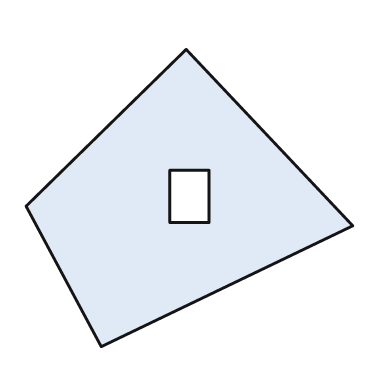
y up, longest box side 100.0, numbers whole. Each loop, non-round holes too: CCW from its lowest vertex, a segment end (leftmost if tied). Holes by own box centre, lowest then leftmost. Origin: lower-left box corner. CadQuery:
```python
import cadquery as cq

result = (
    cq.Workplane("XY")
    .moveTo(23.0, 0.0)
    .lineTo(100.0, 37.0)
    .lineTo(49.0, 91.0)
    .lineTo(0.0, 43.0)
    .close()
    .moveTo(44.0, 38.0)
    .lineTo(56.0, 38.0)
    .lineTo(56.0, 54.0)
    .lineTo(44.0, 54.0)
    .close()
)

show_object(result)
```